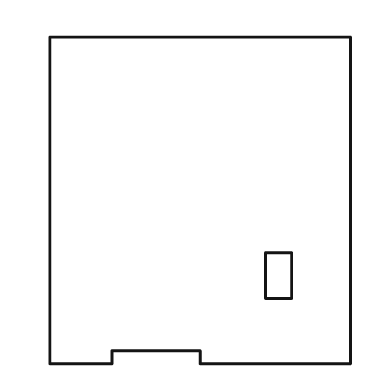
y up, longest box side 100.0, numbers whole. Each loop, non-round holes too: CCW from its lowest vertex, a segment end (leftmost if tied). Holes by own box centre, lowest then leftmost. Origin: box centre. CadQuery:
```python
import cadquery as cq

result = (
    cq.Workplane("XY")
    .moveTo(-46.0, -50.0)
    .lineTo(-27.0, -50.0)
    .lineTo(-27.0, -46.0)
    .lineTo(0.0, -46.0)
    .lineTo(0.0, -50.0)
    .lineTo(46.0, -50.0)
    .lineTo(46.0, 50.0)
    .lineTo(-46.0, 50.0)
    .close()
    .moveTo(20.0, -30.0)
    .lineTo(28.0, -30.0)
    .lineTo(28.0, -16.0)
    .lineTo(20.0, -16.0)
    .close()
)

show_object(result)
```